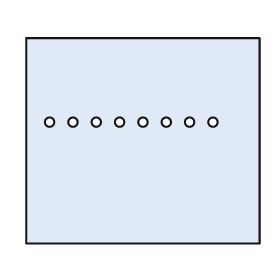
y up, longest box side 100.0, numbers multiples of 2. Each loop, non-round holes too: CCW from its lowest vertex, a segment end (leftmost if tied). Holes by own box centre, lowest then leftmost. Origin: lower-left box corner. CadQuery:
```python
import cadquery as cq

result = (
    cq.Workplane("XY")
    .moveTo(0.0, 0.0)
    .lineTo(100.0, 0.0)
    .lineTo(100.0, 88.0)
    .lineTo(0.0, 88.0)
    .close()
    .moveTo(10.0, 52.0)
    .circle(2.0)
    .moveTo(20.0, 52.0)
    .circle(2.0)
    .moveTo(30.0, 52.0)
    .circle(2.0)
    .moveTo(40.0, 52.0)
    .circle(2.0)
    .moveTo(50.0, 52.0)
    .circle(2.0)
    .moveTo(60.0, 52.0)
    .circle(2.0)
    .moveTo(70.0, 52.0)
    .circle(2.0)
    .moveTo(80.0, 52.0)
    .circle(2.0)
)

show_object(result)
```